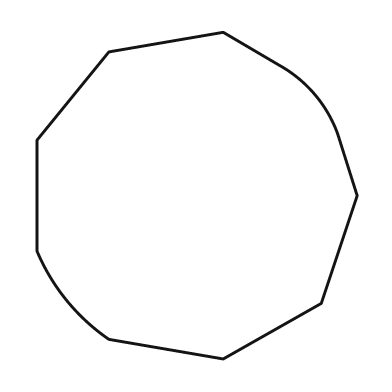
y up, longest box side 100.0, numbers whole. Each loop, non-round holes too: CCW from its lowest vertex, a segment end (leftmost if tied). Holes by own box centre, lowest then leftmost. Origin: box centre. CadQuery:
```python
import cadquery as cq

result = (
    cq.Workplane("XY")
    .moveTo(8.0, -50.0)
    .lineTo(38.0, -33.0)
    .lineTo(49.0, 0.0)
    .lineTo(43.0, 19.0)
    .threePointArc((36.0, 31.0), (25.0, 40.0))
    .lineTo(8.0, 50.0)
    .lineTo(-27.0, 44.0)
    .lineTo(-49.0, 17.0)
    .lineTo(-49.0, -17.0)
    .threePointArc((-40.0, -32.0), (-27.0, -44.0))
    .close()
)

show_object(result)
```